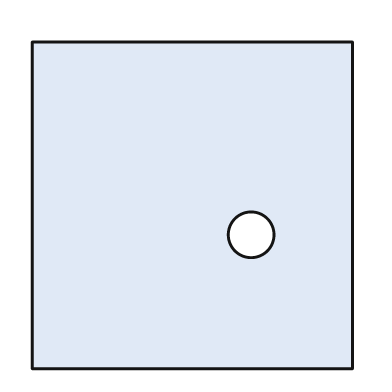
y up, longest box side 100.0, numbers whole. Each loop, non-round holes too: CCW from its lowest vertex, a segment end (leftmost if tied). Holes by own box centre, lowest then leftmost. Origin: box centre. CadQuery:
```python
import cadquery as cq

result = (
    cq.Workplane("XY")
    .moveTo(-49.0, -50.0)
    .lineTo(49.0, -50.0)
    .lineTo(49.0, 50.0)
    .lineTo(-49.0, 50.0)
    .close()
    .moveTo(18.0, -9.0)
    .circle(7.0)
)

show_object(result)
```